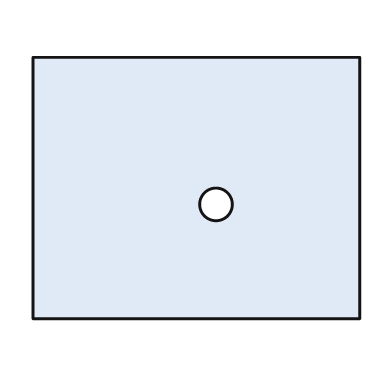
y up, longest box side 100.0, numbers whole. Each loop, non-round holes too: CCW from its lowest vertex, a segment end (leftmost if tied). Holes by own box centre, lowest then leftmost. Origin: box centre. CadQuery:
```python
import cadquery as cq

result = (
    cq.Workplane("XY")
    .moveTo(-50.0, -40.0)
    .lineTo(50.0, -40.0)
    .lineTo(50.0, 40.0)
    .lineTo(-50.0, 40.0)
    .close()
    .moveTo(6.0, -5.0)
    .circle(5.0)
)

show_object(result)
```